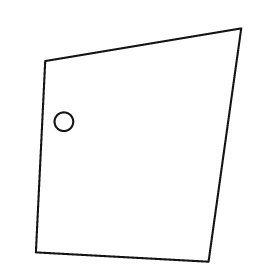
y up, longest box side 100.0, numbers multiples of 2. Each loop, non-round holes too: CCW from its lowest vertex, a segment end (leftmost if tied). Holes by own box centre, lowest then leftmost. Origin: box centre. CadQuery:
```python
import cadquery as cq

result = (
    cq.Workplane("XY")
    .moveTo(30.0, -50.0)
    .lineTo(44.0, 50.0)
    .lineTo(-40.0, 36.0)
    .lineTo(-44.0, -46.0)
    .close()
    .moveTo(-32.0, 10.0)
    .circle(4.0)
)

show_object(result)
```